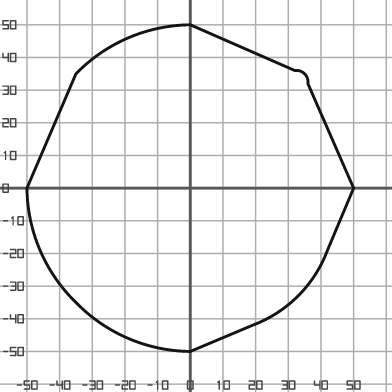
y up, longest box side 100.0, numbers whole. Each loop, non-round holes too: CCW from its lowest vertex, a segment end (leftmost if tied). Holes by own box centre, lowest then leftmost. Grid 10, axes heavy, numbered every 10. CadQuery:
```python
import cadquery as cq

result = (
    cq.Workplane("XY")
    .moveTo(0.0, -50.0)
    .lineTo(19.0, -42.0)
    .threePointArc((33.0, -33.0), (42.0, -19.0))
    .lineTo(50.0, 0.0)
    .lineTo(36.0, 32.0)
    .threePointArc((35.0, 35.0), (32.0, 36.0))
    .lineTo(0.0, 50.0)
    .threePointArc((-19.0, 46.0), (-35.0, 35.0))
    .lineTo(-50.0, 0.0)
    .threePointArc((-46.0, -19.0), (-35.0, -35.0))
    .threePointArc((-19.0, -46.0), (0.0, -50.0))
    .close()
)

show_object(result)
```